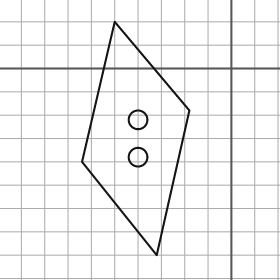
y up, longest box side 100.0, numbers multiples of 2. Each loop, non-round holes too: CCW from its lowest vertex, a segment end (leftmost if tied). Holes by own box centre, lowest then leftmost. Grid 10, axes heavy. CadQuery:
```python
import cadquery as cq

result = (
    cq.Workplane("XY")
    .moveTo(-32.0, -80.0)
    .lineTo(-18.0, -18.0)
    .lineTo(-50.0, 20.0)
    .lineTo(-64.0, -40.0)
    .close()
    .moveTo(-40.0, -38.0)
    .circle(4.0)
    .moveTo(-40.0, -22.0)
    .circle(4.0)
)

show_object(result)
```